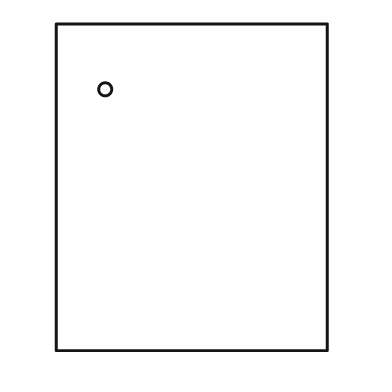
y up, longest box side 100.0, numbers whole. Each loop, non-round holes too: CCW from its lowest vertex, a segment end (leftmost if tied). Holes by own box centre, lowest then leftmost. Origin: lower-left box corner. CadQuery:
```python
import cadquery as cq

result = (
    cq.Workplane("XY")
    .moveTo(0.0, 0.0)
    .lineTo(83.0, 0.0)
    .lineTo(83.0, 100.0)
    .lineTo(0.0, 100.0)
    .close()
    .moveTo(15.0, 80.0)
    .circle(2.0)
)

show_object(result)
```